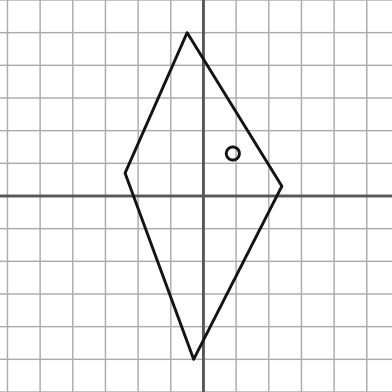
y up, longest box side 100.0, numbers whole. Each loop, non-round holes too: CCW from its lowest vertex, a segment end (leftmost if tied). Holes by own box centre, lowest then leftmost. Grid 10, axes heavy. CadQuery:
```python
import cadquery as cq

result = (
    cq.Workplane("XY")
    .moveTo(-3.0, -50.0)
    .lineTo(24.0, 3.0)
    .lineTo(-5.0, 50.0)
    .lineTo(-24.0, 7.0)
    .close()
    .moveTo(9.0, 13.0)
    .circle(2.0)
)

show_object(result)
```